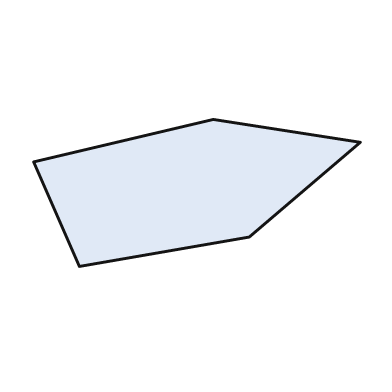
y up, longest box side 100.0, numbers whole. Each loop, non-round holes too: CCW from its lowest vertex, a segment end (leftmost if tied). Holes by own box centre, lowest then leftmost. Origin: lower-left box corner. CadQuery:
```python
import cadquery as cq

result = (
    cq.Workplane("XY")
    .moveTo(14.0, 0.0)
    .lineTo(66.0, 9.0)
    .lineTo(100.0, 38.0)
    .lineTo(55.0, 45.0)
    .lineTo(0.0, 32.0)
    .close()
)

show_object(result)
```